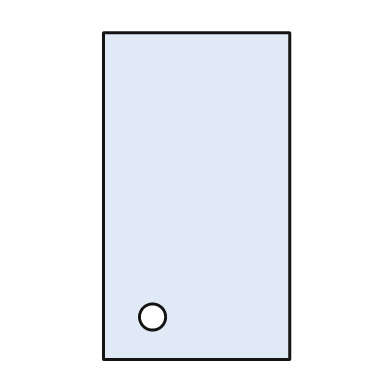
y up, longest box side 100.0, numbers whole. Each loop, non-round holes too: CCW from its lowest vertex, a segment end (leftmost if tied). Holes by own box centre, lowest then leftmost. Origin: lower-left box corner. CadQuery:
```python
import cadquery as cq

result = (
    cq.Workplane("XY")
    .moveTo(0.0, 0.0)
    .lineTo(57.0, 0.0)
    .lineTo(57.0, 100.0)
    .lineTo(0.0, 100.0)
    .close()
    .moveTo(15.0, 13.0)
    .circle(4.0)
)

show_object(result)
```